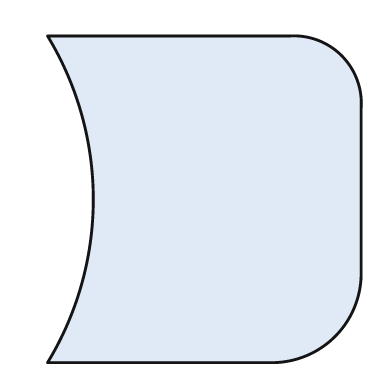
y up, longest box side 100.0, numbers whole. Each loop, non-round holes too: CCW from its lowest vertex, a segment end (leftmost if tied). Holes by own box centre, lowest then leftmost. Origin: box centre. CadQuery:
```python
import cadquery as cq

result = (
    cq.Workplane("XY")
    .moveTo(-48.0, -50.0)
    .lineTo(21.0, -50.0)
    .threePointArc((40.0, -42.0), (48.0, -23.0))
    .lineTo(48.0, 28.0)
    .threePointArc((42.0, 44.0), (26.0, 50.0))
    .lineTo(-48.0, 50.0)
    .threePointArc((-34.0, 0.0), (-48.0, -50.0))
    .close()
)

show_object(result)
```